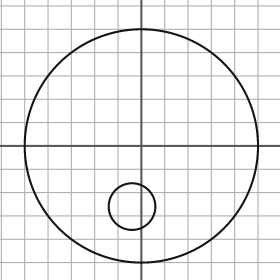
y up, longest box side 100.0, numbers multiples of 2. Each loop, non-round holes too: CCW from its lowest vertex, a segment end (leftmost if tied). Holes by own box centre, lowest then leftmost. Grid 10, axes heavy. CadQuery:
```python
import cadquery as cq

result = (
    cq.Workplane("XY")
    .moveTo(0.0, 0.0)
    .circle(50.0)
    .moveTo(-4.0, -26.0)
    .circle(10.0)
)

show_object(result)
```